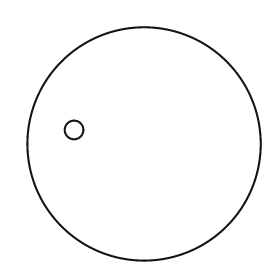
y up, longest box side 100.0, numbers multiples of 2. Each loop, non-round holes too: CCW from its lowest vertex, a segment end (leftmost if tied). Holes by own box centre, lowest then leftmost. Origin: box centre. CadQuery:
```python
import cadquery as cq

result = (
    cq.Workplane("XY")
    .moveTo(0.0, 0.0)
    .circle(50.0)
    .moveTo(-30.0, 6.0)
    .circle(4.0)
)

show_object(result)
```